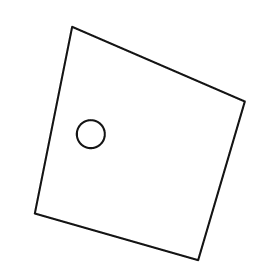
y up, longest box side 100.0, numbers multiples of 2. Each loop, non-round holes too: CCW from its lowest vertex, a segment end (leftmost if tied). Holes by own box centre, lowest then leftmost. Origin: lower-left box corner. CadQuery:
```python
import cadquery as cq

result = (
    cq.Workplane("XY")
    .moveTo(70.0, 0.0)
    .lineTo(90.0, 68.0)
    .lineTo(16.0, 100.0)
    .lineTo(0.0, 20.0)
    .close()
    .moveTo(24.0, 54.0)
    .circle(6.0)
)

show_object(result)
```